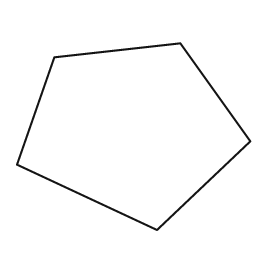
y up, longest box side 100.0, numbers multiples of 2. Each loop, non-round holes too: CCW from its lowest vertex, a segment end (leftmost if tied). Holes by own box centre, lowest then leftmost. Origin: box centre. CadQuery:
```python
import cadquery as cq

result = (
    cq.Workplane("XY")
    .moveTo(10.0, -40.0)
    .lineTo(50.0, -2.0)
    .lineTo(20.0, 40.0)
    .lineTo(-34.0, 34.0)
    .lineTo(-50.0, -12.0)
    .close()
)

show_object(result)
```